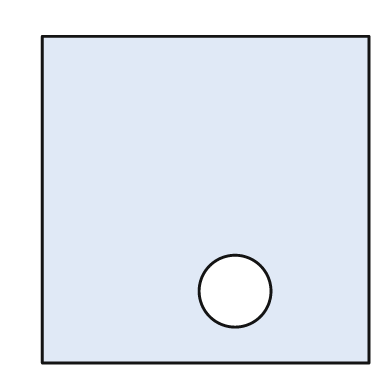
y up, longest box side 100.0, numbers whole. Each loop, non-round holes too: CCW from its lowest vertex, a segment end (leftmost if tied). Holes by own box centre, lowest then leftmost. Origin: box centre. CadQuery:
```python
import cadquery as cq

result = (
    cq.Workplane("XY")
    .moveTo(-50.0, -50.0)
    .lineTo(50.0, -50.0)
    .lineTo(50.0, 50.0)
    .lineTo(-50.0, 50.0)
    .close()
    .moveTo(9.0, -28.0)
    .circle(11.0)
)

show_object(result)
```